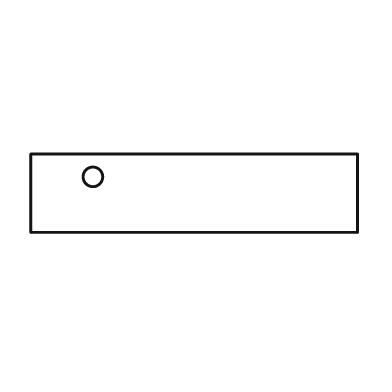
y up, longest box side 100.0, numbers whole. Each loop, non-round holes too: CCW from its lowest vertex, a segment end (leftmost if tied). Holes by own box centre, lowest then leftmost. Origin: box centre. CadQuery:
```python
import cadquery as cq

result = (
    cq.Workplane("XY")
    .moveTo(-50.0, -12.0)
    .lineTo(50.0, -12.0)
    .lineTo(50.0, 12.0)
    .lineTo(-50.0, 12.0)
    .close()
    .moveTo(-31.0, 5.0)
    .circle(3.0)
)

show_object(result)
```